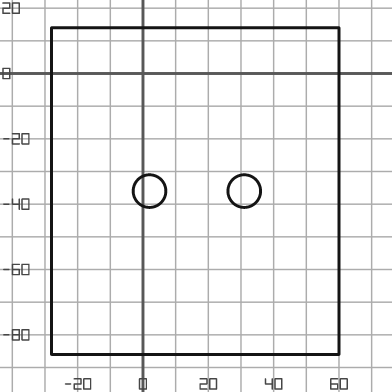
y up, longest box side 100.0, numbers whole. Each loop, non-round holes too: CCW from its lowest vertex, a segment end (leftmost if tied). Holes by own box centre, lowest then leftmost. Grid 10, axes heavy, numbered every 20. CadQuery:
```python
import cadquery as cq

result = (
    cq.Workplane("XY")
    .moveTo(-28.0, -86.0)
    .lineTo(60.0, -86.0)
    .lineTo(60.0, 14.0)
    .lineTo(-28.0, 14.0)
    .close()
    .moveTo(2.0, -36.0)
    .circle(5.0)
    .moveTo(31.0, -36.0)
    .circle(5.0)
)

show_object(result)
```